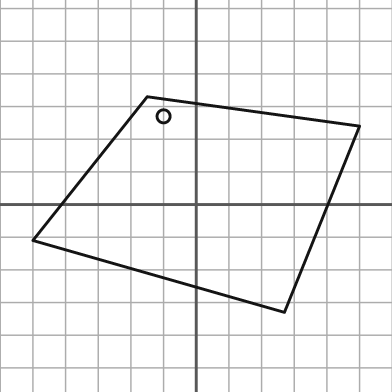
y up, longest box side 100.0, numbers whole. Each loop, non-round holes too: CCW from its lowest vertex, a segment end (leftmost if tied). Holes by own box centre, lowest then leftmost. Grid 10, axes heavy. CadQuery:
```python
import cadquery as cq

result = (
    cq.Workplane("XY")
    .moveTo(27.0, -33.0)
    .lineTo(50.0, 24.0)
    .lineTo(-15.0, 33.0)
    .lineTo(-50.0, -11.0)
    .close()
    .moveTo(-10.0, 27.0)
    .circle(2.0)
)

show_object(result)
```